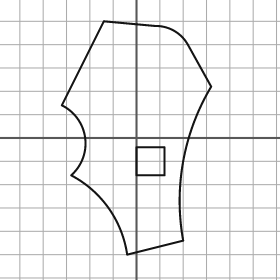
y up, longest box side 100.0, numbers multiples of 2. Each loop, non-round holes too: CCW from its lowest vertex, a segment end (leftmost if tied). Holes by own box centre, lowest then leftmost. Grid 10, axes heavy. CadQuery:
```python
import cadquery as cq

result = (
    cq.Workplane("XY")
    .moveTo(-4.0, -50.0)
    .lineTo(20.0, -44.0)
    .threePointArc((20.0, -10.0), (32.0, 22.0))
    .lineTo(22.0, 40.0)
    .threePointArc((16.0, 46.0), (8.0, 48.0))
    .lineTo(-14.0, 50.0)
    .lineTo(-32.0, 14.0)
    .threePointArc((-22.0, 0.0), (-28.0, -16.0))
    .threePointArc((-12.0, -30.0), (-4.0, -50.0))
    .close()
    .moveTo(0.0, -16.0)
    .lineTo(12.0, -16.0)
    .lineTo(12.0, -4.0)
    .lineTo(0.0, -4.0)
    .close()
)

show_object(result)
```